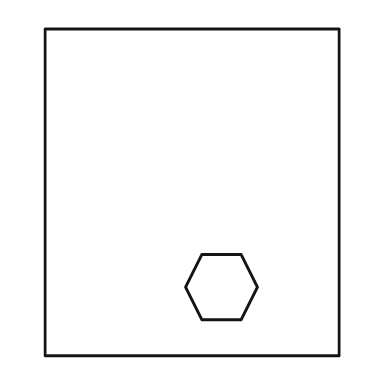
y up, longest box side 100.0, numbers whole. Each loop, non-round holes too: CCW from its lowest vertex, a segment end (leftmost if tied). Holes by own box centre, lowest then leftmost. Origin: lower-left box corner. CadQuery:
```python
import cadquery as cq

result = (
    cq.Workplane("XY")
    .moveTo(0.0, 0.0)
    .lineTo(90.0, 0.0)
    .lineTo(90.0, 100.0)
    .lineTo(0.0, 100.0)
    .close()
    .moveTo(48.0, 11.0)
    .lineTo(60.0, 11.0)
    .lineTo(65.0, 21.0)
    .lineTo(60.0, 31.0)
    .lineTo(48.0, 31.0)
    .lineTo(43.0, 21.0)
    .close()
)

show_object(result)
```